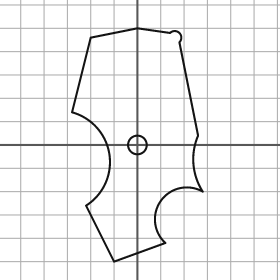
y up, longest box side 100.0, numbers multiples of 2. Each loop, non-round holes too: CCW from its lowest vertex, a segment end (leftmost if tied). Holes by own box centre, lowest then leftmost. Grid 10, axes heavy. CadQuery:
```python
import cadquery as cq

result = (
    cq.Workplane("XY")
    .moveTo(-10.0, -50.0)
    .lineTo(12.0, -42.0)
    .threePointArc((10.0, -24.0), (28.0, -20.0))
    .threePointArc((24.0, -8.0), (26.0, 4.0))
    .lineTo(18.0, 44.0)
    .threePointArc((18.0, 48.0), (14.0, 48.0))
    .lineTo(0.0, 50.0)
    .lineTo(-20.0, 46.0)
    .lineTo(-28.0, 14.0)
    .threePointArc((-12.0, -4.0), (-22.0, -26.0))
    .close()
    .moveTo(0.0, 0.0)
    .circle(4.0)
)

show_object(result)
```